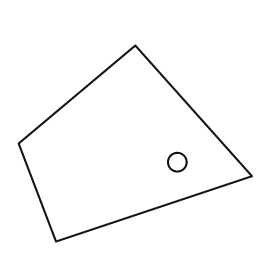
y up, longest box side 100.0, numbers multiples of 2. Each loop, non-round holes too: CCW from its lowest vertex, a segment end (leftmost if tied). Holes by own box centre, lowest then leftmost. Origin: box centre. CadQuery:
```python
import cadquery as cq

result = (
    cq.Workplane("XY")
    .moveTo(-34.0, -42.0)
    .lineTo(50.0, -14.0)
    .lineTo(0.0, 42.0)
    .lineTo(-50.0, 0.0)
    .close()
    .moveTo(18.0, -8.0)
    .circle(4.0)
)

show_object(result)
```